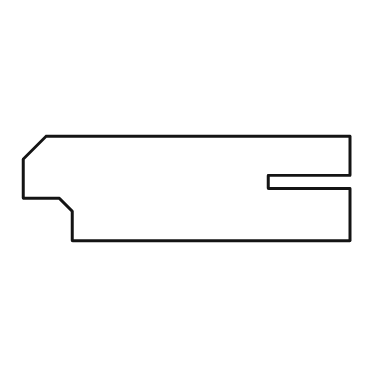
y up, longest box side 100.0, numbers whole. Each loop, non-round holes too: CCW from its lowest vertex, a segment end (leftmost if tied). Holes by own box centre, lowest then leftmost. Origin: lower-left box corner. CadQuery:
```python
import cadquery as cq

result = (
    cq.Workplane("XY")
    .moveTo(15.0, 0.0)
    .lineTo(100.0, 0.0)
    .lineTo(100.0, 16.0)
    .lineTo(75.0, 16.0)
    .lineTo(75.0, 20.0)
    .lineTo(100.0, 20.0)
    .lineTo(100.0, 32.0)
    .lineTo(7.0, 32.0)
    .lineTo(0.0, 25.0)
    .lineTo(0.0, 13.0)
    .lineTo(11.0, 13.0)
    .lineTo(15.0, 9.0)
    .close()
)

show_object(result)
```